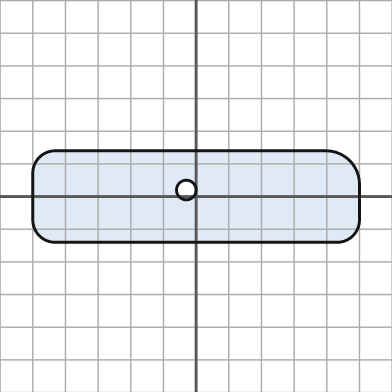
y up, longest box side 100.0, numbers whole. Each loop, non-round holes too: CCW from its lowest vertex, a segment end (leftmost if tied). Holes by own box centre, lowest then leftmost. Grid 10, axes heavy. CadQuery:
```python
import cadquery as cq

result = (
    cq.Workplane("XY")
    .moveTo(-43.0, -14.0)
    .lineTo(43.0, -14.0)
    .threePointArc((48.0, -12.0), (50.0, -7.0))
    .lineTo(50.0, 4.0)
    .threePointArc((47.0, 11.0), (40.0, 14.0))
    .lineTo(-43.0, 14.0)
    .threePointArc((-48.0, 12.0), (-50.0, 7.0))
    .lineTo(-50.0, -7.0)
    .threePointArc((-48.0, -12.0), (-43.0, -14.0))
    .close()
    .moveTo(-3.0, 2.0)
    .circle(3.0)
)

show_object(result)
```